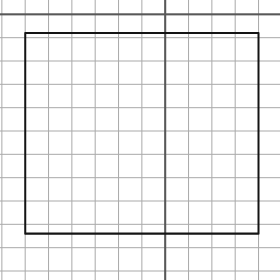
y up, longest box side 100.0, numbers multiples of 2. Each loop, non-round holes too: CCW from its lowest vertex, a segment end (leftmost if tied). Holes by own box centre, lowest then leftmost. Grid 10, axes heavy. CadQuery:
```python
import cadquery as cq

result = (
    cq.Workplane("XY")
    .moveTo(-60.0, -94.0)
    .lineTo(40.0, -94.0)
    .lineTo(40.0, -8.0)
    .lineTo(-60.0, -8.0)
    .close()
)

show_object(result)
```